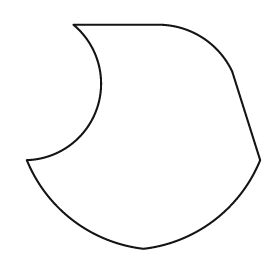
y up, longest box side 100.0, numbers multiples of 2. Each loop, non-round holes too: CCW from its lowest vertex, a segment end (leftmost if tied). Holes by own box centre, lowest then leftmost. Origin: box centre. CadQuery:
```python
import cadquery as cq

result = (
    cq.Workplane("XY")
    .moveTo(0.0, -48.0)
    .threePointArc((30.0, -36.0), (50.0, -10.0))
    .lineTo(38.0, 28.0)
    .threePointArc((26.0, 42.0), (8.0, 48.0))
    .lineTo(-30.0, 48.0)
    .threePointArc((-20.0, 12.0), (-50.0, -10.0))
    .threePointArc((-30.0, -36.0), (0.0, -48.0))
    .close()
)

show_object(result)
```